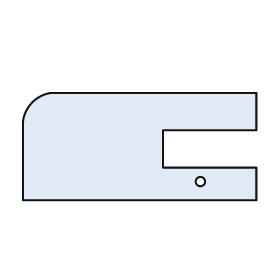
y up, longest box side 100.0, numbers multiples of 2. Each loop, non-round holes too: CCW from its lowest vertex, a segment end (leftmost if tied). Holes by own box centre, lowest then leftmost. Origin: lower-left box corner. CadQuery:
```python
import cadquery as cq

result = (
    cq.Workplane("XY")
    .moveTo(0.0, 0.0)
    .lineTo(100.0, 0.0)
    .lineTo(100.0, 14.0)
    .lineTo(60.0, 14.0)
    .lineTo(60.0, 30.0)
    .lineTo(100.0, 30.0)
    .lineTo(100.0, 46.0)
    .lineTo(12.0, 46.0)
    .threePointArc((4.0, 42.0), (0.0, 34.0))
    .close()
    .moveTo(76.0, 8.0)
    .circle(2.0)
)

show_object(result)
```